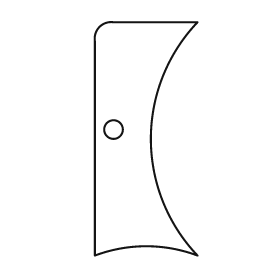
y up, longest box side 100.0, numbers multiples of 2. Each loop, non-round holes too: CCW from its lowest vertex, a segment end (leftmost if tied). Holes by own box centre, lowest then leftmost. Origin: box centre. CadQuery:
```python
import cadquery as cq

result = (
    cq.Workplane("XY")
    .moveTo(-22.0, -50.0)
    .threePointArc((0.0, -46.0), (22.0, -50.0))
    .threePointArc((2.0, 0.0), (22.0, 50.0))
    .lineTo(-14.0, 50.0)
    .threePointArc((-20.0, 48.0), (-22.0, 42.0))
    .close()
    .moveTo(-14.0, 4.0)
    .circle(4.0)
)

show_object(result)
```